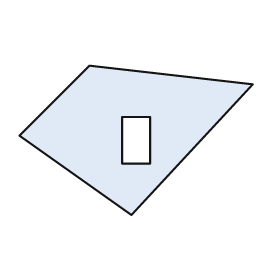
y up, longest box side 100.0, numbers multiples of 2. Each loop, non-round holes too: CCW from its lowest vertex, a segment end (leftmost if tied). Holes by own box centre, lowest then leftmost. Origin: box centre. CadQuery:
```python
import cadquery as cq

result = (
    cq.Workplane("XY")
    .moveTo(-2.0, -32.0)
    .lineTo(50.0, 24.0)
    .lineTo(-20.0, 32.0)
    .lineTo(-50.0, 2.0)
    .close()
    .moveTo(-6.0, -10.0)
    .lineTo(6.0, -10.0)
    .lineTo(6.0, 10.0)
    .lineTo(-6.0, 10.0)
    .close()
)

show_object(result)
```